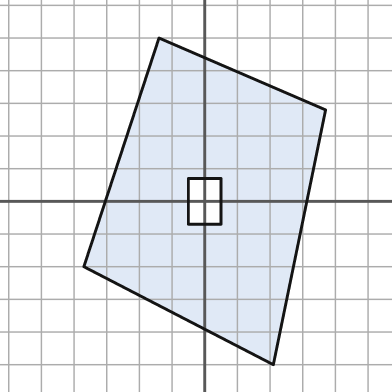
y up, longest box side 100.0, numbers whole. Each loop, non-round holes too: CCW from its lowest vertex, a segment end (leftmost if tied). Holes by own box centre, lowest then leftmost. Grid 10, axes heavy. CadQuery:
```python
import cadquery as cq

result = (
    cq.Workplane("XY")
    .moveTo(21.0, -50.0)
    .lineTo(37.0, 28.0)
    .lineTo(-14.0, 50.0)
    .lineTo(-37.0, -20.0)
    .close()
    .moveTo(-5.0, -7.0)
    .lineTo(5.0, -7.0)
    .lineTo(5.0, 7.0)
    .lineTo(-5.0, 7.0)
    .close()
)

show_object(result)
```